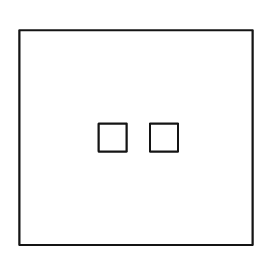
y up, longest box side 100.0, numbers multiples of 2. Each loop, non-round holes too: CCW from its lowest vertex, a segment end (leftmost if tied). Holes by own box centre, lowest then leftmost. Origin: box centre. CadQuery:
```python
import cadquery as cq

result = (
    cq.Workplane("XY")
    .moveTo(-50.0, -46.0)
    .lineTo(50.0, -46.0)
    .lineTo(50.0, 46.0)
    .lineTo(-50.0, 46.0)
    .close()
    .moveTo(-16.0, -6.0)
    .lineTo(-4.0, -6.0)
    .lineTo(-4.0, 6.0)
    .lineTo(-16.0, 6.0)
    .close()
    .moveTo(6.0, -6.0)
    .lineTo(18.0, -6.0)
    .lineTo(18.0, 6.0)
    .lineTo(6.0, 6.0)
    .close()
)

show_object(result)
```